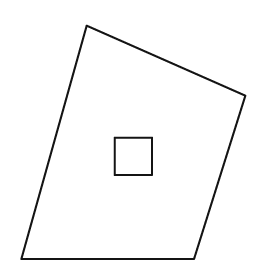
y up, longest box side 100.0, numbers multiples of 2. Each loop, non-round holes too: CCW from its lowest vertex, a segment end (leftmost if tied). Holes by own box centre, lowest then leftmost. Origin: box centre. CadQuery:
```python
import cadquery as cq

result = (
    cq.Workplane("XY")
    .moveTo(-48.0, -50.0)
    .lineTo(26.0, -50.0)
    .lineTo(48.0, 20.0)
    .lineTo(-20.0, 50.0)
    .close()
    .moveTo(-8.0, -14.0)
    .lineTo(8.0, -14.0)
    .lineTo(8.0, 2.0)
    .lineTo(-8.0, 2.0)
    .close()
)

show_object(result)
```